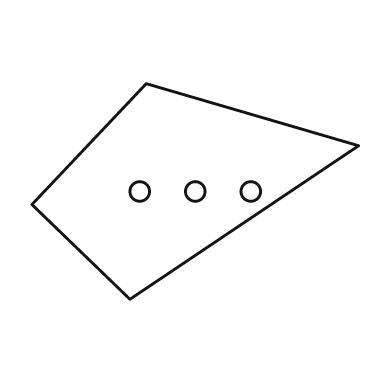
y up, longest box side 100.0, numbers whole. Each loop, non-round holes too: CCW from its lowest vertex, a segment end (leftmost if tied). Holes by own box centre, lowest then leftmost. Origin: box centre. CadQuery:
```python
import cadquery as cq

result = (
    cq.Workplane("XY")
    .moveTo(-20.0, -33.0)
    .lineTo(50.0, 14.0)
    .lineTo(-15.0, 33.0)
    .lineTo(-50.0, -4.0)
    .close()
    .moveTo(-17.0, 0.0)
    .circle(3.0)
    .moveTo(0.0, 0.0)
    .circle(3.0)
    .moveTo(17.0, 0.0)
    .circle(3.0)
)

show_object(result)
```